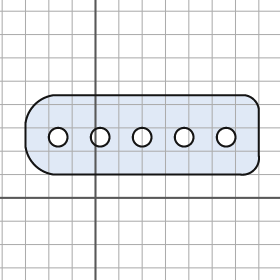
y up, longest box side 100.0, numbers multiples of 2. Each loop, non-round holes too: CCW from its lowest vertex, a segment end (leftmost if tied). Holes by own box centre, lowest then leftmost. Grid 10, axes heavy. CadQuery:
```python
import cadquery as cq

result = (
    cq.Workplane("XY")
    .moveTo(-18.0, 10.0)
    .lineTo(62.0, 10.0)
    .threePointArc((68.0, 12.0), (70.0, 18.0))
    .lineTo(70.0, 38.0)
    .threePointArc((68.0, 42.0), (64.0, 44.0))
    .lineTo(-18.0, 44.0)
    .threePointArc((-26.0, 40.0), (-30.0, 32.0))
    .lineTo(-30.0, 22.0)
    .threePointArc((-26.0, 14.0), (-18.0, 10.0))
    .close()
    .moveTo(-16.0, 26.0)
    .circle(4.0)
    .moveTo(2.0, 26.0)
    .circle(4.0)
    .moveTo(20.0, 26.0)
    .circle(4.0)
    .moveTo(38.0, 26.0)
    .circle(4.0)
    .moveTo(56.0, 26.0)
    .circle(4.0)
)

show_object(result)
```